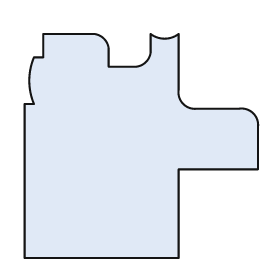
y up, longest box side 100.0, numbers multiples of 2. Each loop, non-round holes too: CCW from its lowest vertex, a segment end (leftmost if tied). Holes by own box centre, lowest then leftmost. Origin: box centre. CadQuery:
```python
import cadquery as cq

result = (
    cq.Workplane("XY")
    .moveTo(-50.0, -48.0)
    .lineTo(16.0, -48.0)
    .lineTo(16.0, -10.0)
    .lineTo(50.0, -10.0)
    .lineTo(50.0, 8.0)
    .threePointArc((48.0, 14.0), (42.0, 16.0))
    .lineTo(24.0, 16.0)
    .threePointArc((18.0, 18.0), (16.0, 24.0))
    .lineTo(16.0, 48.0)
    .threePointArc((10.0, 46.0), (4.0, 48.0))
    .lineTo(4.0, 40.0)
    .threePointArc((2.0, 36.0), (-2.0, 34.0))
    .lineTo(-14.0, 34.0)
    .lineTo(-14.0, 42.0)
    .threePointArc((-16.0, 46.0), (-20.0, 48.0))
    .lineTo(-42.0, 48.0)
    .lineTo(-42.0, 38.0)
    .lineTo(-46.0, 38.0)
    .threePointArc((-48.0, 28.0), (-46.0, 18.0))
    .lineTo(-50.0, 18.0)
    .close()
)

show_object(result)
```